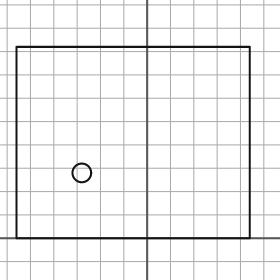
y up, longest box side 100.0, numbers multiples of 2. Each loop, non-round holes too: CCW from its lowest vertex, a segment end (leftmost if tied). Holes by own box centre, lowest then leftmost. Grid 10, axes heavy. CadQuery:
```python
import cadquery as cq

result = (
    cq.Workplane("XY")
    .moveTo(-56.0, 0.0)
    .lineTo(44.0, 0.0)
    .lineTo(44.0, 82.0)
    .lineTo(-56.0, 82.0)
    .close()
    .moveTo(-28.0, 28.0)
    .circle(4.0)
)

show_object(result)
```